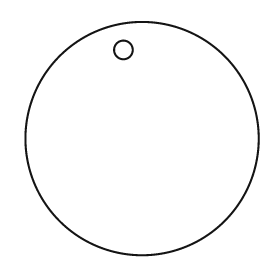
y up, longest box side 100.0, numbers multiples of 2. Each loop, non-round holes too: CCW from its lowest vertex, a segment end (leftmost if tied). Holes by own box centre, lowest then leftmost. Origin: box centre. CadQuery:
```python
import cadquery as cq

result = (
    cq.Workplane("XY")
    .moveTo(0.0, 0.0)
    .circle(50.0)
    .moveTo(-8.0, 38.0)
    .circle(4.0)
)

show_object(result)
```